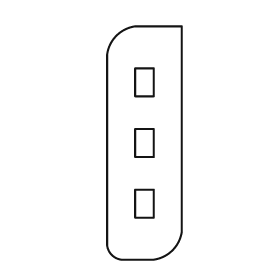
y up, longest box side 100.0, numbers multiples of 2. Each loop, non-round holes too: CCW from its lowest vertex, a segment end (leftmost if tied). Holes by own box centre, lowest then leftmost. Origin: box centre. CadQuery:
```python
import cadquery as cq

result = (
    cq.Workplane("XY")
    .moveTo(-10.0, -50.0)
    .lineTo(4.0, -50.0)
    .threePointArc((12.0, -46.0), (16.0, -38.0))
    .lineTo(16.0, 50.0)
    .lineTo(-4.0, 50.0)
    .threePointArc((-12.0, 46.0), (-16.0, 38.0))
    .lineTo(-16.0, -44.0)
    .threePointArc((-14.0, -48.0), (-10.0, -50.0))
    .close()
    .moveTo(-4.0, -32.0)
    .lineTo(4.0, -32.0)
    .lineTo(4.0, -20.0)
    .lineTo(-4.0, -20.0)
    .close()
    .moveTo(-4.0, -6.0)
    .lineTo(4.0, -6.0)
    .lineTo(4.0, 6.0)
    .lineTo(-4.0, 6.0)
    .close()
    .moveTo(-4.0, 20.0)
    .lineTo(4.0, 20.0)
    .lineTo(4.0, 32.0)
    .lineTo(-4.0, 32.0)
    .close()
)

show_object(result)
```